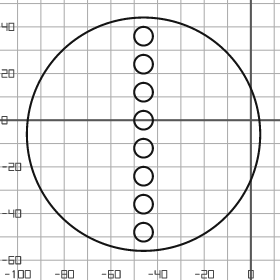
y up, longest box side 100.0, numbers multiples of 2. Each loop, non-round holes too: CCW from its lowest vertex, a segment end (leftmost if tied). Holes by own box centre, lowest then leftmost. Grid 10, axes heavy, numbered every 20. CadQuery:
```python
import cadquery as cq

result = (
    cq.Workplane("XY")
    .moveTo(-46.0, -6.0)
    .circle(50.0)
    .moveTo(-46.0, -48.0)
    .circle(4.0)
    .moveTo(-46.0, -36.0)
    .circle(4.0)
    .moveTo(-46.0, -24.0)
    .circle(4.0)
    .moveTo(-46.0, -12.0)
    .circle(4.0)
    .moveTo(-46.0, 0.0)
    .circle(4.0)
    .moveTo(-46.0, 12.0)
    .circle(4.0)
    .moveTo(-46.0, 24.0)
    .circle(4.0)
    .moveTo(-46.0, 36.0)
    .circle(4.0)
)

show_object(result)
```